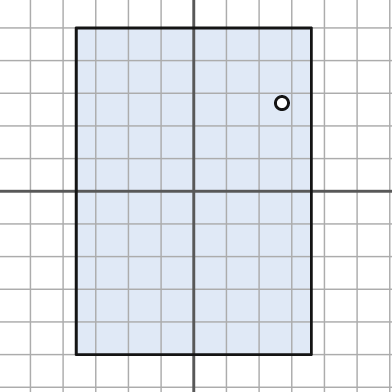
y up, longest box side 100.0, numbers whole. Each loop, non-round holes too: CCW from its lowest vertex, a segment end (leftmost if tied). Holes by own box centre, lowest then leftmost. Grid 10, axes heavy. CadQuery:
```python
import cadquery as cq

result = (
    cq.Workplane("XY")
    .moveTo(-36.0, -50.0)
    .lineTo(36.0, -50.0)
    .lineTo(36.0, 50.0)
    .lineTo(-36.0, 50.0)
    .close()
    .moveTo(27.0, 27.0)
    .circle(2.0)
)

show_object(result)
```